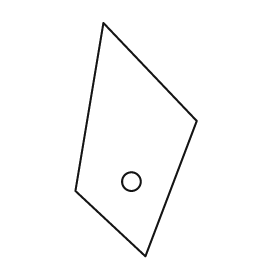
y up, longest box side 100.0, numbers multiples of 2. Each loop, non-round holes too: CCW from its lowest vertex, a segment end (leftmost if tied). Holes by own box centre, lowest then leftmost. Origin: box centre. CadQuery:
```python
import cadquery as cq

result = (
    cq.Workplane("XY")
    .moveTo(4.0, -50.0)
    .lineTo(26.0, 8.0)
    .lineTo(-14.0, 50.0)
    .lineTo(-26.0, -22.0)
    .close()
    .moveTo(-2.0, -18.0)
    .circle(4.0)
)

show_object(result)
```